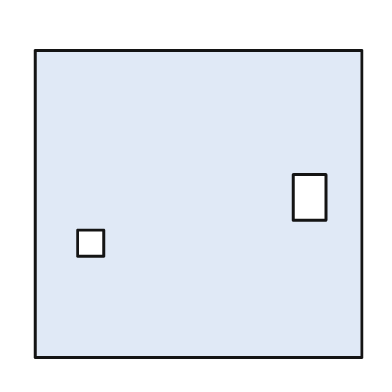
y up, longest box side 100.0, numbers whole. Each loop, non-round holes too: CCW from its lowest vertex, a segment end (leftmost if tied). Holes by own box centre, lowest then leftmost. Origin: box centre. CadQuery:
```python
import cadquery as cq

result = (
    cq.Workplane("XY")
    .moveTo(-50.0, -47.0)
    .lineTo(50.0, -47.0)
    .lineTo(50.0, 47.0)
    .lineTo(-50.0, 47.0)
    .close()
    .moveTo(-37.0, -16.0)
    .lineTo(-29.0, -16.0)
    .lineTo(-29.0, -8.0)
    .lineTo(-37.0, -8.0)
    .close()
    .moveTo(29.0, -5.0)
    .lineTo(39.0, -5.0)
    .lineTo(39.0, 9.0)
    .lineTo(29.0, 9.0)
    .close()
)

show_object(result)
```